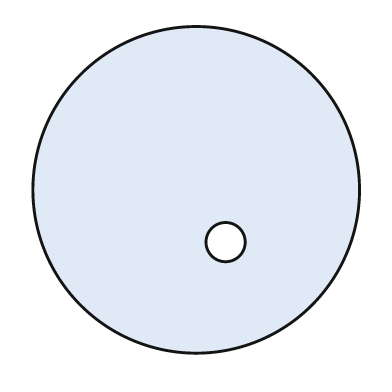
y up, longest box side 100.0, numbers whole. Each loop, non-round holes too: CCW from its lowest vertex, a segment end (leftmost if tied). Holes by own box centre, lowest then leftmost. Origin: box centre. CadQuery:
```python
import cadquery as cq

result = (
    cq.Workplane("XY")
    .moveTo(0.0, 0.0)
    .circle(50.0)
    .moveTo(9.0, -16.0)
    .circle(6.0)
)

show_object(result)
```